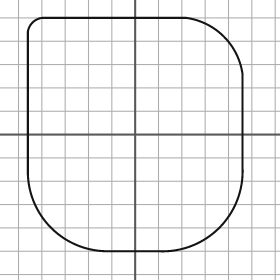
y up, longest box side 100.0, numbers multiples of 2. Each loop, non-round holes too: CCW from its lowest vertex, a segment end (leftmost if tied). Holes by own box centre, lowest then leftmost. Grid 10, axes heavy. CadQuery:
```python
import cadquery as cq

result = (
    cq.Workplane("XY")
    .moveTo(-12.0, -50.0)
    .lineTo(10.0, -50.0)
    .threePointArc((36.0, -40.0), (46.0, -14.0))
    .lineTo(46.0, 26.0)
    .threePointArc((38.0, 42.0), (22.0, 50.0))
    .lineTo(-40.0, 50.0)
    .threePointArc((-44.0, 48.0), (-46.0, 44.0))
    .lineTo(-46.0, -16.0)
    .threePointArc((-36.0, -40.0), (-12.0, -50.0))
    .close()
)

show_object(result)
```